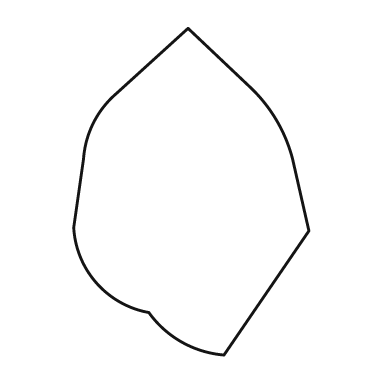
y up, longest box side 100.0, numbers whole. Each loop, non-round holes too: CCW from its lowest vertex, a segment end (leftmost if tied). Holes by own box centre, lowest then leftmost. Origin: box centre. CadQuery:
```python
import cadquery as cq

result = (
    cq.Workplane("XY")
    .moveTo(10.0, -50.0)
    .lineTo(36.0, -12.0)
    .lineTo(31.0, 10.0)
    .threePointArc((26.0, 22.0), (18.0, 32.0))
    .lineTo(-1.0, 50.0)
    .lineTo(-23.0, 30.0)
    .threePointArc((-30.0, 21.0), (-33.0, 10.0))
    .lineTo(-36.0, -11.0)
    .threePointArc((-29.0, -28.0), (-13.0, -37.0))
    .threePointArc((-3.0, -46.0), (10.0, -50.0))
    .close()
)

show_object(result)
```